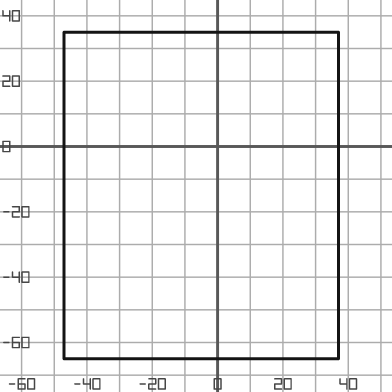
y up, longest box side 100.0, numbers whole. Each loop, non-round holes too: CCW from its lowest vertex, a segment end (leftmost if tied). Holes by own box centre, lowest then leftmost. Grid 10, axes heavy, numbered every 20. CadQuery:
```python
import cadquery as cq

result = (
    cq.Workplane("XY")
    .moveTo(-47.0, -65.0)
    .lineTo(37.0, -65.0)
    .lineTo(37.0, 35.0)
    .lineTo(-47.0, 35.0)
    .close()
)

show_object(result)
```